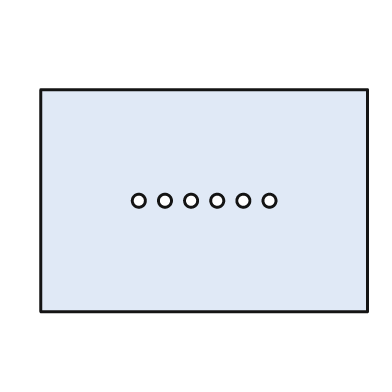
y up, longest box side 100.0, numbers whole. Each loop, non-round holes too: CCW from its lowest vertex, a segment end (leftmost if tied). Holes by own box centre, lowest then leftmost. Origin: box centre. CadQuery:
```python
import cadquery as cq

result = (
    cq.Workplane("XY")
    .moveTo(-50.0, -34.0)
    .lineTo(50.0, -34.0)
    .lineTo(50.0, 34.0)
    .lineTo(-50.0, 34.0)
    .close()
    .moveTo(-20.0, 0.0)
    .circle(2.0)
    .moveTo(-12.0, 0.0)
    .circle(2.0)
    .moveTo(-4.0, 0.0)
    .circle(2.0)
    .moveTo(4.0, 0.0)
    .circle(2.0)
    .moveTo(12.0, 0.0)
    .circle(2.0)
    .moveTo(20.0, 0.0)
    .circle(2.0)
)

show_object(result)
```